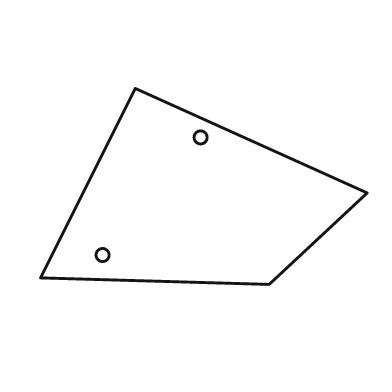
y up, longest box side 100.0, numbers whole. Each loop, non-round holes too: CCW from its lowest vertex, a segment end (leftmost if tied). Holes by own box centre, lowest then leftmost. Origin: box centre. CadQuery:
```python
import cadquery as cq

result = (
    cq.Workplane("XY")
    .moveTo(20.0, -30.0)
    .lineTo(50.0, -2.0)
    .lineTo(-21.0, 30.0)
    .lineTo(-50.0, -28.0)
    .close()
    .moveTo(-31.0, -21.0)
    .circle(2.0)
    .moveTo(-1.0, 15.0)
    .circle(2.0)
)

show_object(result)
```